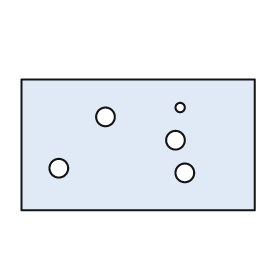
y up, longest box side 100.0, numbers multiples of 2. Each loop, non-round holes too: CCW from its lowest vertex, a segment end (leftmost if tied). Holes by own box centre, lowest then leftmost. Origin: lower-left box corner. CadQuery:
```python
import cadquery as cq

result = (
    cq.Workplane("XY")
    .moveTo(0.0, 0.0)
    .lineTo(100.0, 0.0)
    .lineTo(100.0, 56.0)
    .lineTo(0.0, 56.0)
    .close()
    .moveTo(70.0, 16.0)
    .circle(4.0)
    .moveTo(16.0, 18.0)
    .circle(4.0)
    .moveTo(66.0, 30.0)
    .circle(4.0)
    .moveTo(36.0, 40.0)
    .circle(4.0)
    .moveTo(68.0, 44.0)
    .circle(2.0)
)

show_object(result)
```